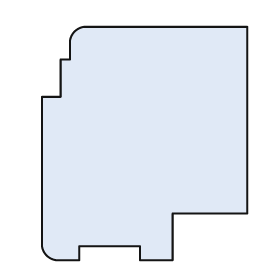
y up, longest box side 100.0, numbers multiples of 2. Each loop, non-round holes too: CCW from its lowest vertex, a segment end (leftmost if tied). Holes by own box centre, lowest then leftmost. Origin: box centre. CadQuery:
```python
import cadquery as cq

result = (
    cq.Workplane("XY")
    .moveTo(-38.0, -50.0)
    .lineTo(-28.0, -50.0)
    .lineTo(-28.0, -44.0)
    .lineTo(-2.0, -44.0)
    .lineTo(-2.0, -50.0)
    .lineTo(12.0, -50.0)
    .lineTo(12.0, -30.0)
    .lineTo(44.0, -30.0)
    .lineTo(44.0, 50.0)
    .lineTo(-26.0, 50.0)
    .threePointArc((-30.0, 48.0), (-32.0, 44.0))
    .lineTo(-32.0, 36.0)
    .lineTo(-36.0, 36.0)
    .lineTo(-36.0, 20.0)
    .lineTo(-44.0, 20.0)
    .lineTo(-44.0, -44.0)
    .threePointArc((-42.0, -48.0), (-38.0, -50.0))
    .close()
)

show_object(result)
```